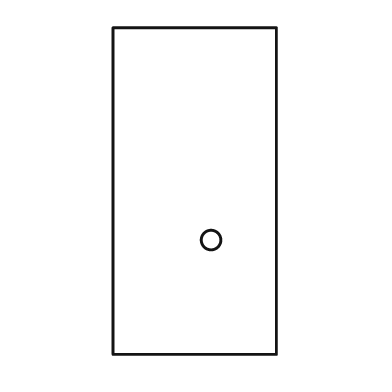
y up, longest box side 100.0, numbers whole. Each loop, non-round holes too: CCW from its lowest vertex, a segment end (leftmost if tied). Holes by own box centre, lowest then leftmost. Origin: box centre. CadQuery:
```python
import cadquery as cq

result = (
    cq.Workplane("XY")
    .moveTo(-25.0, -50.0)
    .lineTo(25.0, -50.0)
    .lineTo(25.0, 50.0)
    .lineTo(-25.0, 50.0)
    .close()
    .moveTo(5.0, -15.0)
    .circle(3.0)
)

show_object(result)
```